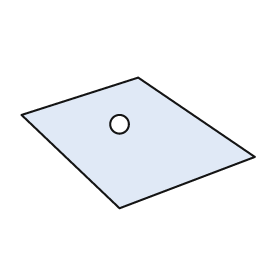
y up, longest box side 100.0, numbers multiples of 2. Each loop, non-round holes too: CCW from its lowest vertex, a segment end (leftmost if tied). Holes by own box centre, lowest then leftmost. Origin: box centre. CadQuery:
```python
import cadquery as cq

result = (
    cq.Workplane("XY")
    .moveTo(-8.0, -28.0)
    .lineTo(50.0, -6.0)
    .lineTo(0.0, 28.0)
    .lineTo(-50.0, 12.0)
    .close()
    .moveTo(-8.0, 8.0)
    .circle(4.0)
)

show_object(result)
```